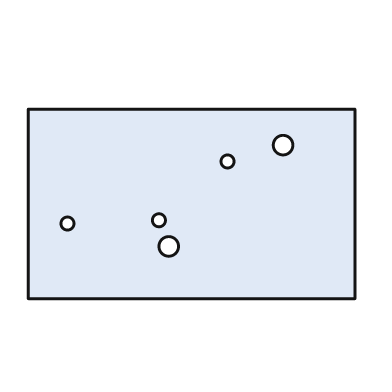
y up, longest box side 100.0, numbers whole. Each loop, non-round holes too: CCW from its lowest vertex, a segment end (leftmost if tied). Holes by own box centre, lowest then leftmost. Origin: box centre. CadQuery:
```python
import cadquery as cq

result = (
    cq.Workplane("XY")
    .moveTo(-50.0, -29.0)
    .lineTo(50.0, -29.0)
    .lineTo(50.0, 29.0)
    .lineTo(-50.0, 29.0)
    .close()
    .moveTo(-7.0, -13.0)
    .circle(3.0)
    .moveTo(-38.0, -6.0)
    .circle(2.0)
    .moveTo(-10.0, -5.0)
    .circle(2.0)
    .moveTo(11.0, 13.0)
    .circle(2.0)
    .moveTo(28.0, 18.0)
    .circle(3.0)
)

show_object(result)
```